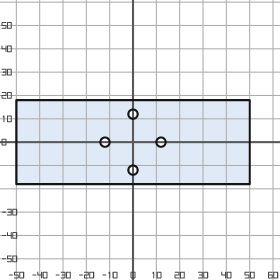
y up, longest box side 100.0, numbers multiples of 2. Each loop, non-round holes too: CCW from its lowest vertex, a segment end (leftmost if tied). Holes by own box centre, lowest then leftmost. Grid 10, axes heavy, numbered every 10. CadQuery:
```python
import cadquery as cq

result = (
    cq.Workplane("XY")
    .moveTo(-50.0, -18.0)
    .lineTo(50.0, -18.0)
    .lineTo(50.0, 18.0)
    .lineTo(-50.0, 18.0)
    .close()
    .moveTo(0.0, -12.0)
    .circle(2.0)
    .moveTo(-12.0, 0.0)
    .circle(2.0)
    .moveTo(12.0, 0.0)
    .circle(2.0)
    .moveTo(0.0, 12.0)
    .circle(2.0)
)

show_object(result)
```